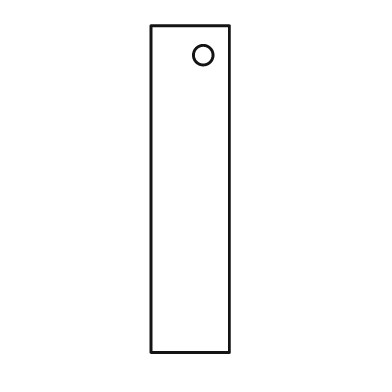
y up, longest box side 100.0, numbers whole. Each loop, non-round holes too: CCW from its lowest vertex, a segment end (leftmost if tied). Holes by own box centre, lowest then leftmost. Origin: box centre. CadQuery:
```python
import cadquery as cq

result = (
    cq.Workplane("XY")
    .moveTo(-12.0, -50.0)
    .lineTo(12.0, -50.0)
    .lineTo(12.0, 50.0)
    .lineTo(-12.0, 50.0)
    .close()
    .moveTo(4.0, 41.0)
    .circle(3.0)
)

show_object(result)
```